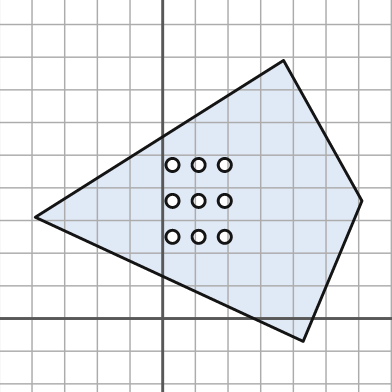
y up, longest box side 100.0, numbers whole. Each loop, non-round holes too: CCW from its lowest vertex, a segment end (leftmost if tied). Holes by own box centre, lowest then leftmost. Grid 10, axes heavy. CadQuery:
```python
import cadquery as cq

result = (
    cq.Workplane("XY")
    .moveTo(43.0, -7.0)
    .lineTo(61.0, 36.0)
    .lineTo(37.0, 79.0)
    .lineTo(-39.0, 31.0)
    .close()
    .moveTo(3.0, 25.0)
    .circle(2.0)
    .moveTo(11.0, 25.0)
    .circle(2.0)
    .moveTo(19.0, 25.0)
    .circle(2.0)
    .moveTo(3.0, 36.0)
    .circle(2.0)
    .moveTo(11.0, 36.0)
    .circle(2.0)
    .moveTo(19.0, 36.0)
    .circle(2.0)
    .moveTo(3.0, 47.0)
    .circle(2.0)
    .moveTo(11.0, 47.0)
    .circle(2.0)
    .moveTo(19.0, 47.0)
    .circle(2.0)
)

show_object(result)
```